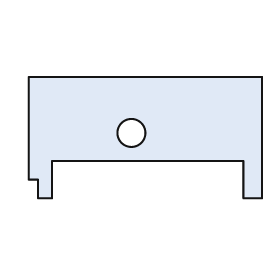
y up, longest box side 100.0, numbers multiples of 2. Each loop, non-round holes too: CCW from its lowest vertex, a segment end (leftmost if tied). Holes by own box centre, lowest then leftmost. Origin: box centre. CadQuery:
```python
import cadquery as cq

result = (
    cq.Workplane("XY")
    .moveTo(-46.0, -26.0)
    .lineTo(-40.0, -26.0)
    .lineTo(-40.0, -10.0)
    .lineTo(42.0, -10.0)
    .lineTo(42.0, -26.0)
    .lineTo(50.0, -26.0)
    .lineTo(50.0, 26.0)
    .lineTo(-50.0, 26.0)
    .lineTo(-50.0, -18.0)
    .lineTo(-46.0, -18.0)
    .close()
    .moveTo(-6.0, 2.0)
    .circle(6.0)
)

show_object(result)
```